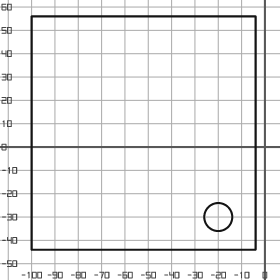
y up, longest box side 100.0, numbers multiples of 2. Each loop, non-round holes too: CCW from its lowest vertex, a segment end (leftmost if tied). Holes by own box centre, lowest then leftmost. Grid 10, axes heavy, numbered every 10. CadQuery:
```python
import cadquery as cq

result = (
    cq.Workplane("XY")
    .moveTo(-100.0, -44.0)
    .lineTo(-4.0, -44.0)
    .lineTo(-4.0, 56.0)
    .lineTo(-100.0, 56.0)
    .close()
    .moveTo(-20.0, -30.0)
    .circle(6.0)
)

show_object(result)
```